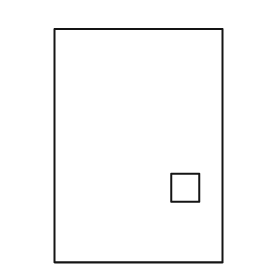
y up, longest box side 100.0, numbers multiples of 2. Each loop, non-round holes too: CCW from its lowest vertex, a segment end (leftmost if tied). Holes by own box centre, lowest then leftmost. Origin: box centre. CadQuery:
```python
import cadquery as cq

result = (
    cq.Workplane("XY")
    .moveTo(-36.0, -50.0)
    .lineTo(36.0, -50.0)
    .lineTo(36.0, 50.0)
    .lineTo(-36.0, 50.0)
    .close()
    .moveTo(14.0, -24.0)
    .lineTo(26.0, -24.0)
    .lineTo(26.0, -12.0)
    .lineTo(14.0, -12.0)
    .close()
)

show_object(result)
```